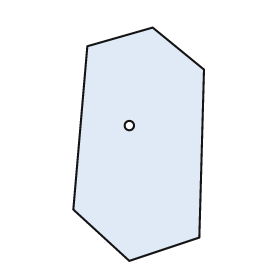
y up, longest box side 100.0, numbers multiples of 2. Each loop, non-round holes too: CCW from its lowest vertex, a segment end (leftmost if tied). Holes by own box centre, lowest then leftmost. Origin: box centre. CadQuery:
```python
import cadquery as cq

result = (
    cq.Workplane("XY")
    .moveTo(-4.0, -50.0)
    .lineTo(26.0, -40.0)
    .lineTo(28.0, 32.0)
    .lineTo(6.0, 50.0)
    .lineTo(-22.0, 42.0)
    .lineTo(-28.0, -28.0)
    .close()
    .moveTo(-4.0, 8.0)
    .circle(2.0)
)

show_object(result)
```